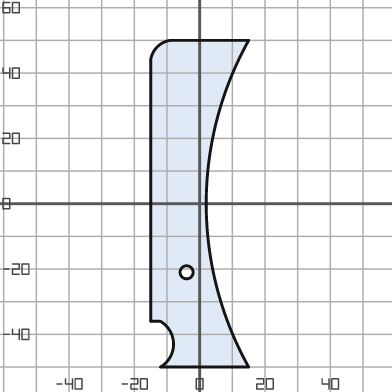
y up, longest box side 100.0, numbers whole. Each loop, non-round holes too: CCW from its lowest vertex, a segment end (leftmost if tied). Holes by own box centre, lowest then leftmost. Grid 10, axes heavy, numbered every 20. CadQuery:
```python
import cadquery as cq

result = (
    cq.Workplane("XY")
    .moveTo(-12.0, -50.0)
    .lineTo(15.0, -50.0)
    .threePointArc((2.0, 0.0), (15.0, 50.0))
    .lineTo(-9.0, 50.0)
    .threePointArc((-13.0, 48.0), (-15.0, 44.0))
    .lineTo(-15.0, -36.0)
    .lineTo(-12.0, -36.0)
    .threePointArc((-8.0, -43.0), (-12.0, -50.0))
    .close()
    .moveTo(-4.0, -21.0)
    .circle(2.0)
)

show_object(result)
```